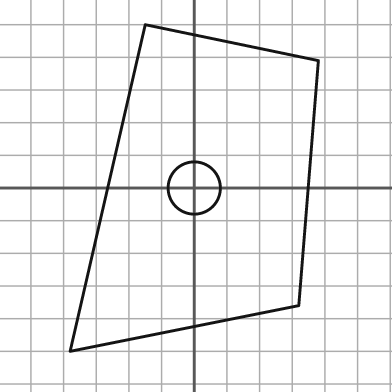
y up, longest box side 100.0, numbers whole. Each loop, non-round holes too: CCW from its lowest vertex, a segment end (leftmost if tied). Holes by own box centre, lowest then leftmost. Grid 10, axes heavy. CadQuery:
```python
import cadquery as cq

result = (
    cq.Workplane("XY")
    .moveTo(-38.0, -50.0)
    .lineTo(32.0, -36.0)
    .lineTo(38.0, 39.0)
    .lineTo(-15.0, 50.0)
    .close()
    .moveTo(0.0, 0.0)
    .circle(8.0)
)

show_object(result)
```